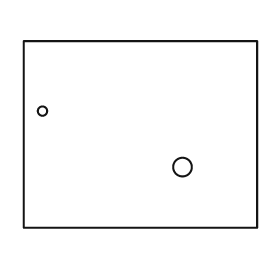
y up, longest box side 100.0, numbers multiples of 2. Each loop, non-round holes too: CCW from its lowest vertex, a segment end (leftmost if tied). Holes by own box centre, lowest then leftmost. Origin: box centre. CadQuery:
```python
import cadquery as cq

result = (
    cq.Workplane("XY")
    .moveTo(-50.0, -40.0)
    .lineTo(50.0, -40.0)
    .lineTo(50.0, 40.0)
    .lineTo(-50.0, 40.0)
    .close()
    .moveTo(18.0, -14.0)
    .circle(4.0)
    .moveTo(-42.0, 10.0)
    .circle(2.0)
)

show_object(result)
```